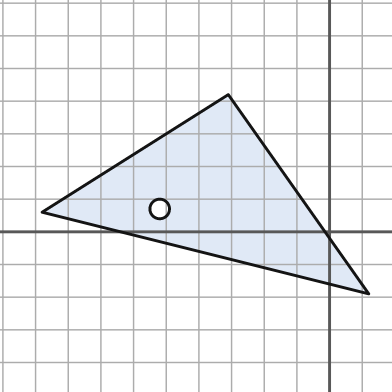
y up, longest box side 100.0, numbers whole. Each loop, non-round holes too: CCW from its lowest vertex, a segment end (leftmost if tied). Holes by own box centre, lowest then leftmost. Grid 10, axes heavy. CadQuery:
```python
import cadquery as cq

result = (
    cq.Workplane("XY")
    .moveTo(12.0, -19.0)
    .lineTo(-31.0, 42.0)
    .lineTo(-88.0, 6.0)
    .close()
    .moveTo(-52.0, 7.0)
    .circle(3.0)
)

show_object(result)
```